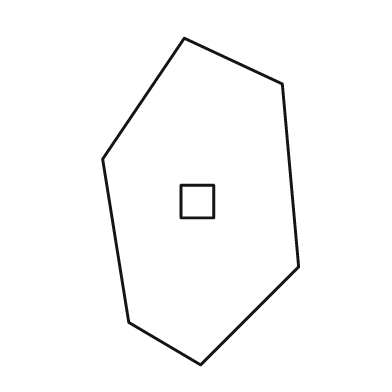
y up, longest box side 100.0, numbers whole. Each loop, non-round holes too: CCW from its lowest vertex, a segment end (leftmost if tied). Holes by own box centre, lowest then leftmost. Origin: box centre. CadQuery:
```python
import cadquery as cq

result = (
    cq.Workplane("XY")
    .moveTo(0.0, -50.0)
    .lineTo(30.0, -20.0)
    .lineTo(25.0, 36.0)
    .lineTo(-5.0, 50.0)
    .lineTo(-30.0, 13.0)
    .lineTo(-22.0, -37.0)
    .close()
    .moveTo(-6.0, -5.0)
    .lineTo(4.0, -5.0)
    .lineTo(4.0, 5.0)
    .lineTo(-6.0, 5.0)
    .close()
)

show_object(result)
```